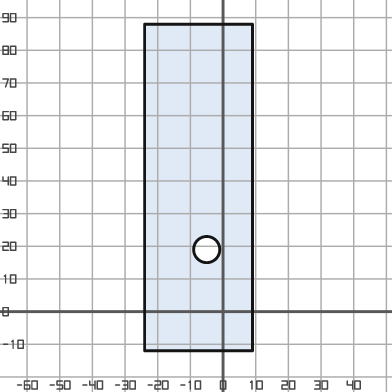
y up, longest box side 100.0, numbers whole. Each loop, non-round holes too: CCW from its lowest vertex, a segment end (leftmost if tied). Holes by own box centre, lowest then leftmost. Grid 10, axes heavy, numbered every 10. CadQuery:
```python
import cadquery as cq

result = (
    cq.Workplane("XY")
    .moveTo(-24.0, -12.0)
    .lineTo(9.0, -12.0)
    .lineTo(9.0, 88.0)
    .lineTo(-24.0, 88.0)
    .close()
    .moveTo(-5.0, 19.0)
    .circle(4.0)
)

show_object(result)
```